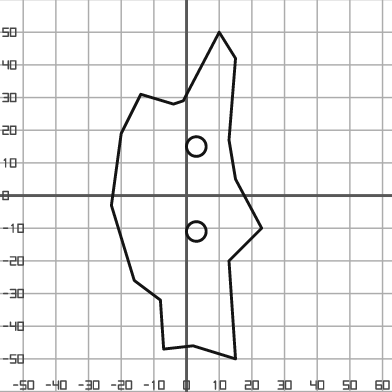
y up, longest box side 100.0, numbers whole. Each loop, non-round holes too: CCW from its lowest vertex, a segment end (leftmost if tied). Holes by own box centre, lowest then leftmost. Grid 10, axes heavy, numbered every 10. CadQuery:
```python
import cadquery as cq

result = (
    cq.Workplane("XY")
    .moveTo(15.0, -50.0)
    .lineTo(13.0, -20.0)
    .lineTo(23.0, -10.0)
    .lineTo(15.0, 5.0)
    .lineTo(13.0, 17.0)
    .lineTo(15.0, 42.0)
    .lineTo(10.0, 50.0)
    .lineTo(-1.0, 29.0)
    .lineTo(-4.0, 28.0)
    .lineTo(-14.0, 31.0)
    .lineTo(-20.0, 19.0)
    .lineTo(-23.0, -3.0)
    .lineTo(-16.0, -26.0)
    .lineTo(-8.0, -32.0)
    .lineTo(-7.0, -47.0)
    .lineTo(2.0, -46.0)
    .close()
    .moveTo(3.0, -11.0)
    .circle(3.0)
    .moveTo(3.0, 15.0)
    .circle(3.0)
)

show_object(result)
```